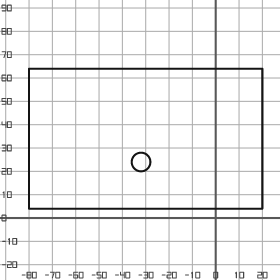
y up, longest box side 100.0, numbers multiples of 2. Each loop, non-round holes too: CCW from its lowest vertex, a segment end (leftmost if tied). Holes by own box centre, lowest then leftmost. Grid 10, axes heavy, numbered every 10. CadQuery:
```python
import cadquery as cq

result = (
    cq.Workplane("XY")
    .moveTo(-80.0, 4.0)
    .lineTo(20.0, 4.0)
    .lineTo(20.0, 64.0)
    .lineTo(-80.0, 64.0)
    .close()
    .moveTo(-32.0, 24.0)
    .circle(4.0)
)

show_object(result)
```